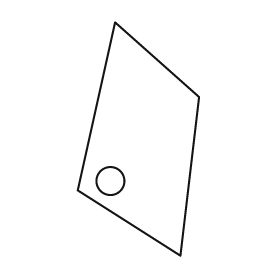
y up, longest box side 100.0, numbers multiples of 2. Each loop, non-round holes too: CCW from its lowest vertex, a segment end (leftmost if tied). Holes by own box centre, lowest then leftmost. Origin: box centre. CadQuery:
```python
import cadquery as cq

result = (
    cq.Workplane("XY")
    .moveTo(18.0, -50.0)
    .lineTo(26.0, 18.0)
    .lineTo(-10.0, 50.0)
    .lineTo(-26.0, -22.0)
    .close()
    .moveTo(-12.0, -18.0)
    .circle(6.0)
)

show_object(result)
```